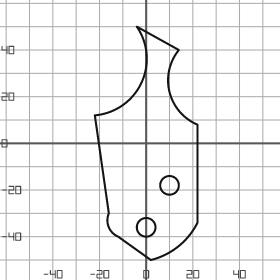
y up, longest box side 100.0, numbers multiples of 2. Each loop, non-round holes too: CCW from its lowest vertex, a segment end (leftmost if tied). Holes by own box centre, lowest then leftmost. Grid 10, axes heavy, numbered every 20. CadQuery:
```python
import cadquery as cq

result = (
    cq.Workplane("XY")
    .moveTo(2.0, -50.0)
    .threePointArc((14.0, -44.0), (22.0, -34.0))
    .lineTo(22.0, 8.0)
    .threePointArc((10.0, 22.0), (14.0, 40.0))
    .lineTo(-4.0, 50.0)
    .threePointArc((-2.0, 26.0), (-22.0, 12.0))
    .lineTo(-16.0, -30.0)
    .threePointArc((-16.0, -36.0), (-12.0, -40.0))
    .close()
    .moveTo(0.0, -36.0)
    .circle(4.0)
    .moveTo(10.0, -18.0)
    .circle(4.0)
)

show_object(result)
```